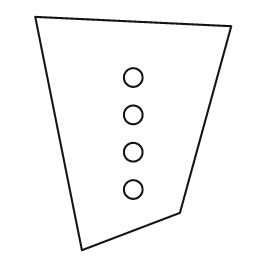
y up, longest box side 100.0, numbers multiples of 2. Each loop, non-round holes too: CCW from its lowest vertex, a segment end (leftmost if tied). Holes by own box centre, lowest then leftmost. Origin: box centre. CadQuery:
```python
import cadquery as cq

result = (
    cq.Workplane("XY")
    .moveTo(-22.0, -50.0)
    .lineTo(20.0, -34.0)
    .lineTo(42.0, 46.0)
    .lineTo(-42.0, 50.0)
    .close()
    .moveTo(0.0, -24.0)
    .circle(4.0)
    .moveTo(0.0, -8.0)
    .circle(4.0)
    .moveTo(0.0, 8.0)
    .circle(4.0)
    .moveTo(0.0, 24.0)
    .circle(4.0)
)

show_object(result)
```